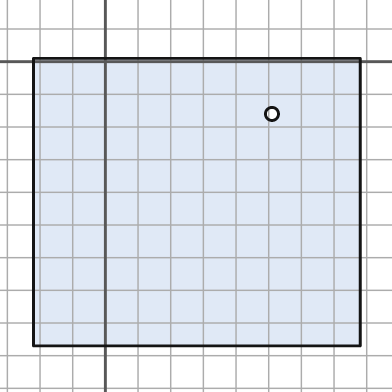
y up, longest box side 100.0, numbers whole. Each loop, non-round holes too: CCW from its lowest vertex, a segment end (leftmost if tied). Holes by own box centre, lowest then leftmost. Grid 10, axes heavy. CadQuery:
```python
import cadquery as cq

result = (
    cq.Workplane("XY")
    .moveTo(-22.0, -87.0)
    .lineTo(78.0, -87.0)
    .lineTo(78.0, 1.0)
    .lineTo(-22.0, 1.0)
    .close()
    .moveTo(51.0, -16.0)
    .circle(2.0)
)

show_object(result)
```